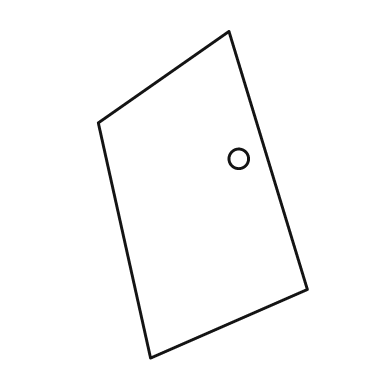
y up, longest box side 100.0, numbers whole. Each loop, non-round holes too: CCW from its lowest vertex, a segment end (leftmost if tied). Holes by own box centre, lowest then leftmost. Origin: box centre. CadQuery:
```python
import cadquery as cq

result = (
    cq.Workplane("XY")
    .moveTo(-16.0, -50.0)
    .lineTo(32.0, -29.0)
    .lineTo(8.0, 50.0)
    .lineTo(-32.0, 22.0)
    .close()
    .moveTo(11.0, 11.0)
    .circle(3.0)
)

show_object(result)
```